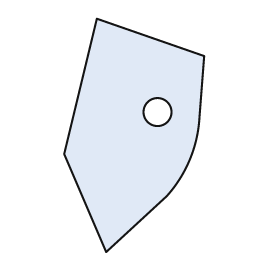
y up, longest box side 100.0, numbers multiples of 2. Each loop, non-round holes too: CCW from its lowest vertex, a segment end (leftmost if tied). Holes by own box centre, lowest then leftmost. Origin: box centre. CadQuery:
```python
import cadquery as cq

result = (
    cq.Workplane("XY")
    .moveTo(-12.0, -50.0)
    .lineTo(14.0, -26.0)
    .threePointArc((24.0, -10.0), (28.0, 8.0))
    .lineTo(30.0, 34.0)
    .lineTo(-16.0, 50.0)
    .lineTo(-30.0, -8.0)
    .close()
    .moveTo(10.0, 10.0)
    .circle(6.0)
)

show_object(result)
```